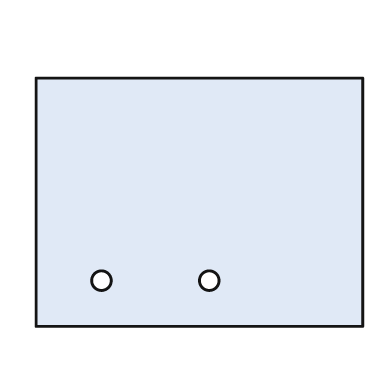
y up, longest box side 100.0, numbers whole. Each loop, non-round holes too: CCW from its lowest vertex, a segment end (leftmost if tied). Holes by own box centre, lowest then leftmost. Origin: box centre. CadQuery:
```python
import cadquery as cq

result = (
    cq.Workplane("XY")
    .moveTo(-50.0, -38.0)
    .lineTo(50.0, -38.0)
    .lineTo(50.0, 38.0)
    .lineTo(-50.0, 38.0)
    .close()
    .moveTo(-30.0, -24.0)
    .circle(3.0)
    .moveTo(3.0, -24.0)
    .circle(3.0)
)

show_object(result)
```